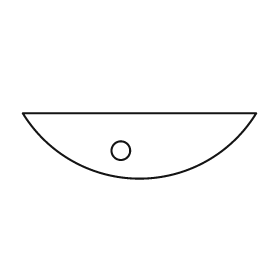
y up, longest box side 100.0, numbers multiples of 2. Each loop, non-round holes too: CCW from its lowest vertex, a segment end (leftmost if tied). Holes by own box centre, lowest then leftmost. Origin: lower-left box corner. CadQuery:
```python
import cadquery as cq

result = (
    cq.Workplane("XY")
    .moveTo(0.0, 28.0)
    .threePointArc((50.0, 0.0), (100.0, 28.0))
    .close()
    .moveTo(42.0, 12.0)
    .circle(4.0)
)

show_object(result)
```